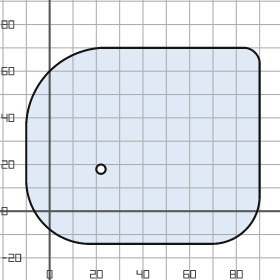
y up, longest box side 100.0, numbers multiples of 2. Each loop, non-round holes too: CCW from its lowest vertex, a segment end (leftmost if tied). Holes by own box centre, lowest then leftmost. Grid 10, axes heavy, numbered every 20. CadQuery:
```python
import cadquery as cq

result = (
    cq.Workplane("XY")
    .moveTo(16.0, -14.0)
    .lineTo(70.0, -14.0)
    .threePointArc((84.0, -8.0), (90.0, 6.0))
    .lineTo(90.0, 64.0)
    .threePointArc((88.0, 68.0), (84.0, 70.0))
    .lineTo(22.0, 70.0)
    .threePointArc((0.0, 60.0), (-10.0, 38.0))
    .lineTo(-10.0, 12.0)
    .threePointArc((-2.0, -6.0), (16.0, -14.0))
    .close()
    .moveTo(22.0, 18.0)
    .circle(2.0)
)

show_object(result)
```